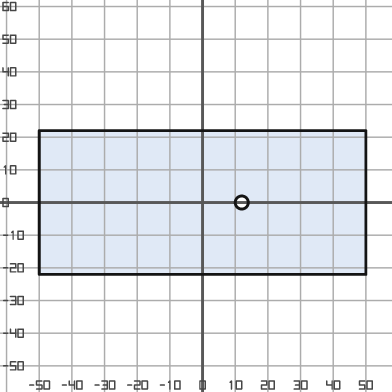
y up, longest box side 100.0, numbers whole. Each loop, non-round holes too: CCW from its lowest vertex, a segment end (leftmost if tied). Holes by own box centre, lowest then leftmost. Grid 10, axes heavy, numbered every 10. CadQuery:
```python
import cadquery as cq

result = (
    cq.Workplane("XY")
    .moveTo(-50.0, -22.0)
    .lineTo(50.0, -22.0)
    .lineTo(50.0, 22.0)
    .lineTo(-50.0, 22.0)
    .close()
    .moveTo(12.0, 0.0)
    .circle(2.0)
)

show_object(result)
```